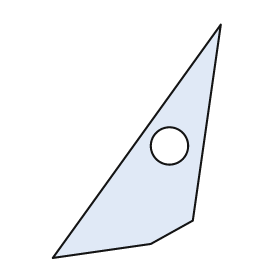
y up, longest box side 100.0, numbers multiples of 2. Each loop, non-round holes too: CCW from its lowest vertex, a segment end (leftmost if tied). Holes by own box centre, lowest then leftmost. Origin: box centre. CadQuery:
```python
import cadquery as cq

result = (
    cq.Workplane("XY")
    .moveTo(-36.0, -50.0)
    .lineTo(6.0, -44.0)
    .lineTo(24.0, -34.0)
    .lineTo(36.0, 50.0)
    .close()
    .moveTo(14.0, -2.0)
    .circle(8.0)
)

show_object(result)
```